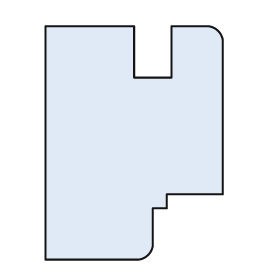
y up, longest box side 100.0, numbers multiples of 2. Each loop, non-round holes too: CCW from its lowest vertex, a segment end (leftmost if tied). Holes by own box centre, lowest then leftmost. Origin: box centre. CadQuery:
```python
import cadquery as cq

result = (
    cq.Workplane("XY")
    .moveTo(-38.0, -50.0)
    .lineTo(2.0, -50.0)
    .threePointArc((6.0, -48.0), (8.0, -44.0))
    .lineTo(8.0, -28.0)
    .lineTo(14.0, -28.0)
    .lineTo(14.0, -22.0)
    .lineTo(38.0, -22.0)
    .lineTo(38.0, 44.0)
    .threePointArc((36.0, 48.0), (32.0, 50.0))
    .lineTo(16.0, 50.0)
    .lineTo(16.0, 28.0)
    .lineTo(0.0, 28.0)
    .lineTo(0.0, 50.0)
    .lineTo(-38.0, 50.0)
    .close()
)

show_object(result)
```